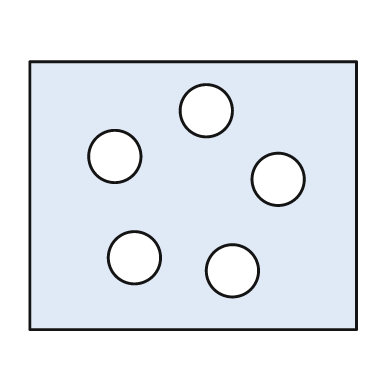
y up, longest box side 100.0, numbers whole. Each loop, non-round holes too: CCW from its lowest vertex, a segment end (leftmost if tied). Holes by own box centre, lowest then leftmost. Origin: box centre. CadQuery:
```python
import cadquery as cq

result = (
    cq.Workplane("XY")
    .moveTo(-50.0, -41.0)
    .lineTo(50.0, -41.0)
    .lineTo(50.0, 41.0)
    .lineTo(-50.0, 41.0)
    .close()
    .moveTo(12.0, -23.0)
    .circle(8.0)
    .moveTo(-18.0, -19.0)
    .circle(8.0)
    .moveTo(26.0, 5.0)
    .circle(8.0)
    .moveTo(-24.0, 12.0)
    .circle(8.0)
    .moveTo(4.0, 26.0)
    .circle(8.0)
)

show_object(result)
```